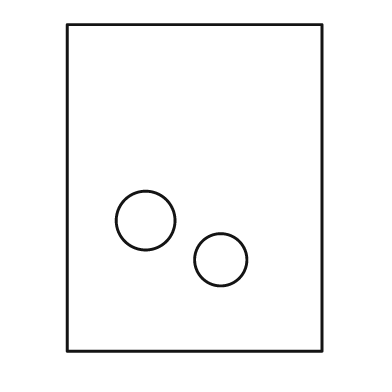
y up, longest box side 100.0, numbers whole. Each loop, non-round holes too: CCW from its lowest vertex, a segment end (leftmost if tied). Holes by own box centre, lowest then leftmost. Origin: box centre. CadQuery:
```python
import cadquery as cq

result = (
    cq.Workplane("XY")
    .moveTo(-39.0, -50.0)
    .lineTo(39.0, -50.0)
    .lineTo(39.0, 50.0)
    .lineTo(-39.0, 50.0)
    .close()
    .moveTo(8.0, -22.0)
    .circle(8.0)
    .moveTo(-15.0, -10.0)
    .circle(9.0)
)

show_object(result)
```